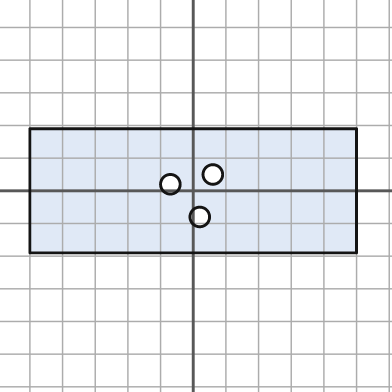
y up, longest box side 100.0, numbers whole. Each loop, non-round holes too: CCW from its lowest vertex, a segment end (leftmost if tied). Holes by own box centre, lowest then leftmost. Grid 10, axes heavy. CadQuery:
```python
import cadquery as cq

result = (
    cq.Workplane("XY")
    .moveTo(-50.0, -19.0)
    .lineTo(50.0, -19.0)
    .lineTo(50.0, 19.0)
    .lineTo(-50.0, 19.0)
    .close()
    .moveTo(2.0, -8.0)
    .circle(3.0)
    .moveTo(-7.0, 2.0)
    .circle(3.0)
    .moveTo(6.0, 5.0)
    .circle(3.0)
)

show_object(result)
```